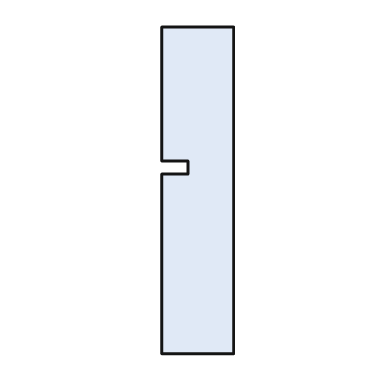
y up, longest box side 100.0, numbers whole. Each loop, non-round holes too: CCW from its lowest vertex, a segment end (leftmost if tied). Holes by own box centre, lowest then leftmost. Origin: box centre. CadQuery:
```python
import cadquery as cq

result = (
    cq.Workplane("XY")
    .moveTo(-11.0, -50.0)
    .lineTo(11.0, -50.0)
    .lineTo(11.0, 50.0)
    .lineTo(-11.0, 50.0)
    .lineTo(-11.0, 9.0)
    .lineTo(-3.0, 9.0)
    .lineTo(-3.0, 5.0)
    .lineTo(-11.0, 5.0)
    .close()
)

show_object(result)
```